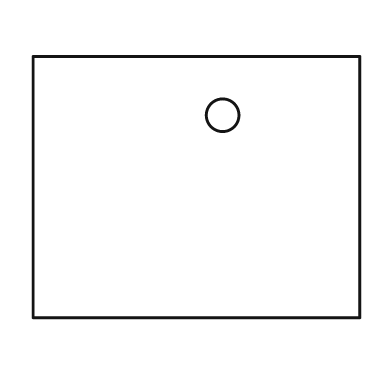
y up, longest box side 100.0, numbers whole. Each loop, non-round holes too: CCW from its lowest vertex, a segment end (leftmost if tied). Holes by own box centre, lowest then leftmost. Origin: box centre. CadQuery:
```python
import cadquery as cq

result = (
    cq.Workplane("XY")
    .moveTo(-50.0, -40.0)
    .lineTo(50.0, -40.0)
    .lineTo(50.0, 40.0)
    .lineTo(-50.0, 40.0)
    .close()
    .moveTo(8.0, 22.0)
    .circle(5.0)
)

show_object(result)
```